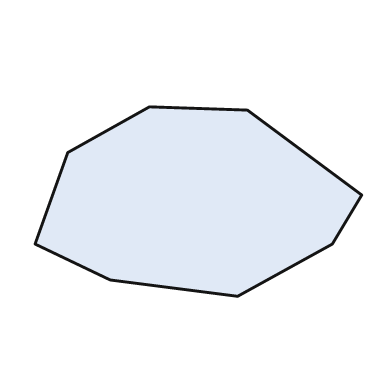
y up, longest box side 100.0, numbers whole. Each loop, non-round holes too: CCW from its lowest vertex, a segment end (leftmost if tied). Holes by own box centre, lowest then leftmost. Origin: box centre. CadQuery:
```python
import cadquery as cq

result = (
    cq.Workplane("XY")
    .moveTo(12.0, -29.0)
    .lineTo(41.0, -13.0)
    .lineTo(50.0, 2.0)
    .lineTo(15.0, 28.0)
    .lineTo(-15.0, 29.0)
    .lineTo(-40.0, 15.0)
    .lineTo(-50.0, -13.0)
    .lineTo(-27.0, -24.0)
    .close()
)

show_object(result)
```